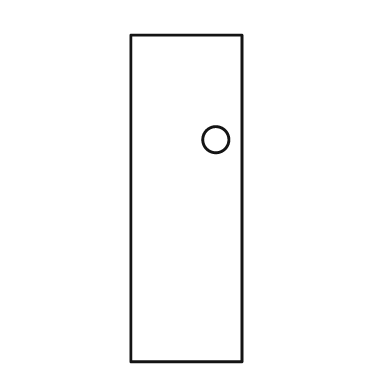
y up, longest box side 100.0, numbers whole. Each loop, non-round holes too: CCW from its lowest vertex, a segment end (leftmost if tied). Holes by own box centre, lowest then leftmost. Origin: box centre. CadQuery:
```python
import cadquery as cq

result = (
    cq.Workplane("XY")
    .moveTo(-17.0, -50.0)
    .lineTo(17.0, -50.0)
    .lineTo(17.0, 50.0)
    .lineTo(-17.0, 50.0)
    .close()
    .moveTo(9.0, 18.0)
    .circle(4.0)
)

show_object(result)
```